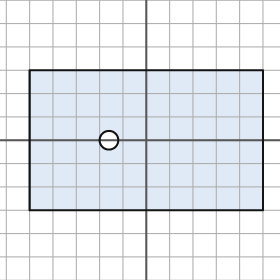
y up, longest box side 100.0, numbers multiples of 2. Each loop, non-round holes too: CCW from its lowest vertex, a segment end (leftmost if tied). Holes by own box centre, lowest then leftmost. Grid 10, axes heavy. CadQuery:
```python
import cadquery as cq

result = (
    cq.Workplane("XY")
    .moveTo(-50.0, -30.0)
    .lineTo(50.0, -30.0)
    .lineTo(50.0, 30.0)
    .lineTo(-50.0, 30.0)
    .close()
    .moveTo(-16.0, 0.0)
    .circle(4.0)
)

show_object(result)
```